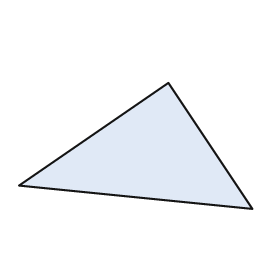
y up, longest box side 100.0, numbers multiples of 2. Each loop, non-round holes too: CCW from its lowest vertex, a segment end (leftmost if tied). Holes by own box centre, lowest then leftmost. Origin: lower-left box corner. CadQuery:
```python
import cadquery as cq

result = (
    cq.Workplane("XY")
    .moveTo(100.0, 0.0)
    .lineTo(64.0, 54.0)
    .lineTo(0.0, 10.0)
    .close()
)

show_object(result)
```